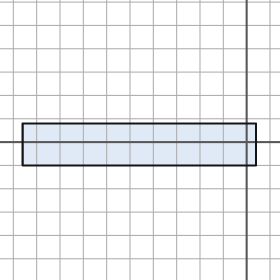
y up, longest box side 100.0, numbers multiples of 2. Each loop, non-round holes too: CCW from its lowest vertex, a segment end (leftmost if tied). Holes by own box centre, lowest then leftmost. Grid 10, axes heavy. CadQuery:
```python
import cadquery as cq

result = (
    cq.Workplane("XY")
    .moveTo(-96.0, -10.0)
    .lineTo(4.0, -10.0)
    .lineTo(4.0, 8.0)
    .lineTo(-96.0, 8.0)
    .close()
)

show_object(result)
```